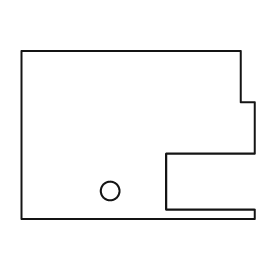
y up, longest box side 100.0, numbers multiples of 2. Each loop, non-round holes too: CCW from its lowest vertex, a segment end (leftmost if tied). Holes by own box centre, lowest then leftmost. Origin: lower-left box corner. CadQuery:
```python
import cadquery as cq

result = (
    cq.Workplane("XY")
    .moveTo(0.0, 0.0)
    .lineTo(100.0, 0.0)
    .lineTo(100.0, 4.0)
    .lineTo(62.0, 4.0)
    .lineTo(62.0, 28.0)
    .lineTo(100.0, 28.0)
    .lineTo(100.0, 50.0)
    .lineTo(94.0, 50.0)
    .lineTo(94.0, 72.0)
    .lineTo(0.0, 72.0)
    .close()
    .moveTo(38.0, 12.0)
    .circle(4.0)
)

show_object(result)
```